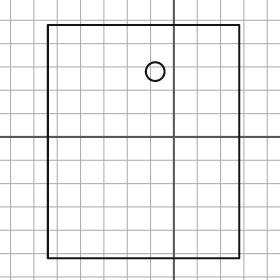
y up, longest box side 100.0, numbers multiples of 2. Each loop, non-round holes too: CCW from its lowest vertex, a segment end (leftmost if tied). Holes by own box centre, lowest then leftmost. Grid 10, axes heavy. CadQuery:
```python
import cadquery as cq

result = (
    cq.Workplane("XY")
    .moveTo(-54.0, -52.0)
    .lineTo(28.0, -52.0)
    .lineTo(28.0, 48.0)
    .lineTo(-54.0, 48.0)
    .close()
    .moveTo(-8.0, 28.0)
    .circle(4.0)
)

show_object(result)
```